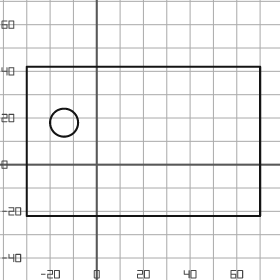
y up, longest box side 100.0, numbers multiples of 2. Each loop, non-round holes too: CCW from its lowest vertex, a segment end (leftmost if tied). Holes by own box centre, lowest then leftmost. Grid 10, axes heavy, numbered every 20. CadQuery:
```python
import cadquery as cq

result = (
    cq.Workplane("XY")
    .moveTo(-30.0, -22.0)
    .lineTo(70.0, -22.0)
    .lineTo(70.0, 42.0)
    .lineTo(-30.0, 42.0)
    .close()
    .moveTo(-14.0, 18.0)
    .circle(6.0)
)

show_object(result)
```